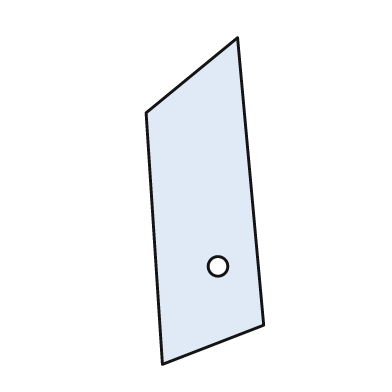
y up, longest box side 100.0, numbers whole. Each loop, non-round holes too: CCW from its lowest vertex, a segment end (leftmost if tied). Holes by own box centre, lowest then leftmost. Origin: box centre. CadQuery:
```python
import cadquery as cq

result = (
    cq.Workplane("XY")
    .moveTo(-13.0, -50.0)
    .lineTo(18.0, -38.0)
    .lineTo(10.0, 50.0)
    .lineTo(-18.0, 27.0)
    .close()
    .moveTo(4.0, -20.0)
    .circle(3.0)
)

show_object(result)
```